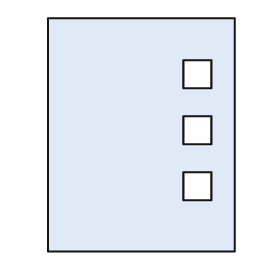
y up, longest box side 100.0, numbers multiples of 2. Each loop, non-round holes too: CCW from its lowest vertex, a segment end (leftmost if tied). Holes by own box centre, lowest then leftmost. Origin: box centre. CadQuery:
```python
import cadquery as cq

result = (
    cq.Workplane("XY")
    .moveTo(-40.0, -50.0)
    .lineTo(40.0, -50.0)
    .lineTo(40.0, 50.0)
    .lineTo(-40.0, 50.0)
    .close()
    .moveTo(18.0, -28.0)
    .lineTo(30.0, -28.0)
    .lineTo(30.0, -16.0)
    .lineTo(18.0, -16.0)
    .close()
    .moveTo(18.0, -4.0)
    .lineTo(30.0, -4.0)
    .lineTo(30.0, 8.0)
    .lineTo(18.0, 8.0)
    .close()
    .moveTo(18.0, 20.0)
    .lineTo(30.0, 20.0)
    .lineTo(30.0, 32.0)
    .lineTo(18.0, 32.0)
    .close()
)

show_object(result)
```